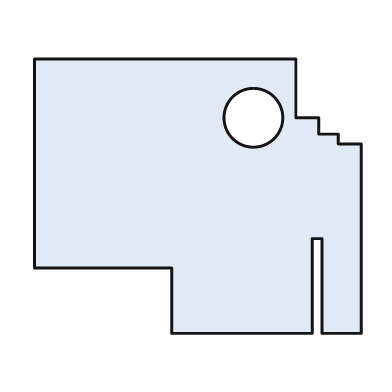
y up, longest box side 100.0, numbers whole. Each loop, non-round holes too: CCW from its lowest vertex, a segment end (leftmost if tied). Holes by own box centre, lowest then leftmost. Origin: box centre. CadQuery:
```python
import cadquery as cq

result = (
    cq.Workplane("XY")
    .moveTo(-8.0, -42.0)
    .lineTo(35.0, -42.0)
    .lineTo(35.0, -13.0)
    .lineTo(38.0, -13.0)
    .lineTo(38.0, -42.0)
    .lineTo(50.0, -42.0)
    .lineTo(50.0, 16.0)
    .lineTo(43.0, 16.0)
    .lineTo(43.0, 19.0)
    .lineTo(37.0, 19.0)
    .lineTo(37.0, 24.0)
    .lineTo(30.0, 24.0)
    .lineTo(30.0, 42.0)
    .lineTo(-50.0, 42.0)
    .lineTo(-50.0, -22.0)
    .lineTo(-8.0, -22.0)
    .close()
    .moveTo(17.0, 24.0)
    .circle(9.0)
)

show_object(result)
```